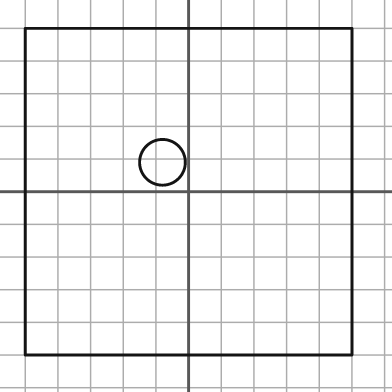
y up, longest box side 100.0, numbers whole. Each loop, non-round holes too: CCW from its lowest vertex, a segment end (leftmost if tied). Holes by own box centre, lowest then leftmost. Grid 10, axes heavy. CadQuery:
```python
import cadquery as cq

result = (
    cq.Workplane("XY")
    .moveTo(-50.0, -50.0)
    .lineTo(50.0, -50.0)
    .lineTo(50.0, 50.0)
    .lineTo(-50.0, 50.0)
    .close()
    .moveTo(-8.0, 9.0)
    .circle(7.0)
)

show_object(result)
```